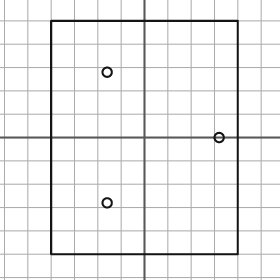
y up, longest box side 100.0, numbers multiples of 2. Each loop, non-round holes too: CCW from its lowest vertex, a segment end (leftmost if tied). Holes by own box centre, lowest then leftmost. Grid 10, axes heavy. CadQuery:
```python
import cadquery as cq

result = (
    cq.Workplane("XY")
    .moveTo(-40.0, -50.0)
    .lineTo(40.0, -50.0)
    .lineTo(40.0, 50.0)
    .lineTo(-40.0, 50.0)
    .close()
    .moveTo(-16.0, -28.0)
    .circle(2.0)
    .moveTo(32.0, 0.0)
    .circle(2.0)
    .moveTo(-16.0, 28.0)
    .circle(2.0)
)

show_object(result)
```